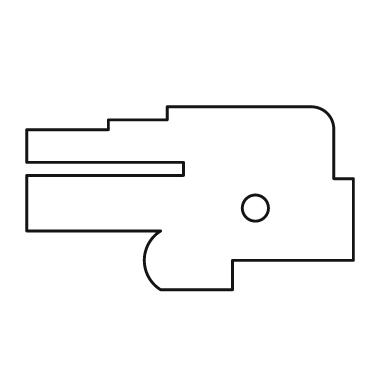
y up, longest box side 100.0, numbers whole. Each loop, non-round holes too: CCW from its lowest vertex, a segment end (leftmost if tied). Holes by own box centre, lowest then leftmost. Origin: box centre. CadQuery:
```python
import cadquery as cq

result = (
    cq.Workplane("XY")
    .moveTo(-9.0, -28.0)
    .lineTo(13.0, -28.0)
    .lineTo(13.0, -19.0)
    .lineTo(50.0, -19.0)
    .lineTo(50.0, 6.0)
    .lineTo(44.0, 6.0)
    .lineTo(44.0, 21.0)
    .threePointArc((42.0, 26.0), (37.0, 28.0))
    .lineTo(-7.0, 28.0)
    .lineTo(-7.0, 24.0)
    .lineTo(-25.0, 24.0)
    .lineTo(-25.0, 21.0)
    .lineTo(-50.0, 21.0)
    .lineTo(-50.0, 11.0)
    .lineTo(-2.0, 11.0)
    .lineTo(-2.0, 7.0)
    .lineTo(-50.0, 7.0)
    .lineTo(-50.0, -10.0)
    .lineTo(-9.0, -10.0)
    .threePointArc((-14.0, -19.0), (-9.0, -28.0))
    .close()
    .moveTo(20.0, -3.0)
    .circle(4.0)
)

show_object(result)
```